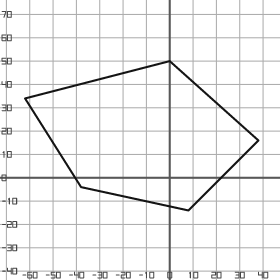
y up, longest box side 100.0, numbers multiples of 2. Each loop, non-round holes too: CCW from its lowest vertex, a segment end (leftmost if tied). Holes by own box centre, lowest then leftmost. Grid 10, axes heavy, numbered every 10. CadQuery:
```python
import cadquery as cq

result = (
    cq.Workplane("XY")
    .moveTo(8.0, -14.0)
    .lineTo(38.0, 16.0)
    .lineTo(0.0, 50.0)
    .lineTo(-62.0, 34.0)
    .lineTo(-38.0, -4.0)
    .close()
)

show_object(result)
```